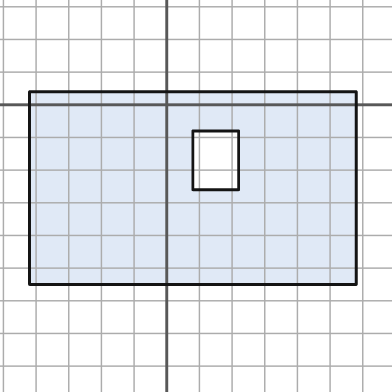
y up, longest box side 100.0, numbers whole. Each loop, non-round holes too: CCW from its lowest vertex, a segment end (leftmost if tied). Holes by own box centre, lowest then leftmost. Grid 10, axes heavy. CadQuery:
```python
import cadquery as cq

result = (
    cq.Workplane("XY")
    .moveTo(-42.0, -55.0)
    .lineTo(58.0, -55.0)
    .lineTo(58.0, 4.0)
    .lineTo(-42.0, 4.0)
    .close()
    .moveTo(8.0, -26.0)
    .lineTo(22.0, -26.0)
    .lineTo(22.0, -8.0)
    .lineTo(8.0, -8.0)
    .close()
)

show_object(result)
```